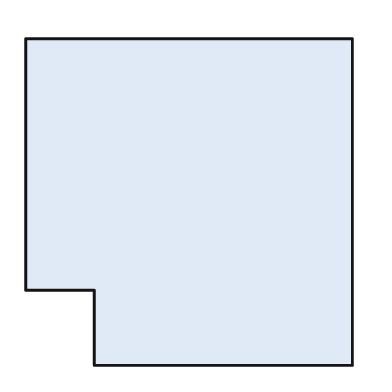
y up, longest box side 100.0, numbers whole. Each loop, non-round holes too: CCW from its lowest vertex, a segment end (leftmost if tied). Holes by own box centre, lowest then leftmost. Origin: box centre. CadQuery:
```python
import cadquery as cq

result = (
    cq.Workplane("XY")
    .moveTo(-29.0, -50.0)
    .lineTo(50.0, -50.0)
    .lineTo(50.0, 50.0)
    .lineTo(-50.0, 50.0)
    .lineTo(-50.0, -27.0)
    .lineTo(-29.0, -27.0)
    .close()
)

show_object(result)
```